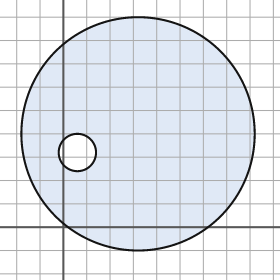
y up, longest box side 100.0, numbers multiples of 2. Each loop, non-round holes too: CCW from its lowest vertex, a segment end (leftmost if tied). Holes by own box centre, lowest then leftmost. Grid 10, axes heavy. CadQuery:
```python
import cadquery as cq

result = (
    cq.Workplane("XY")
    .moveTo(32.0, 40.0)
    .circle(50.0)
    .moveTo(6.0, 32.0)
    .circle(8.0)
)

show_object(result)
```